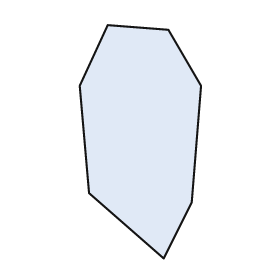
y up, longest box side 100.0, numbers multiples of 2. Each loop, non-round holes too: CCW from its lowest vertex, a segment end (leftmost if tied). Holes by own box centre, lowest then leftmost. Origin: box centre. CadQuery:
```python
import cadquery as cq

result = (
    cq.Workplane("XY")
    .moveTo(10.0, -50.0)
    .lineTo(22.0, -26.0)
    .lineTo(26.0, 24.0)
    .lineTo(12.0, 48.0)
    .lineTo(-14.0, 50.0)
    .lineTo(-26.0, 24.0)
    .lineTo(-22.0, -22.0)
    .close()
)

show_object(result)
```